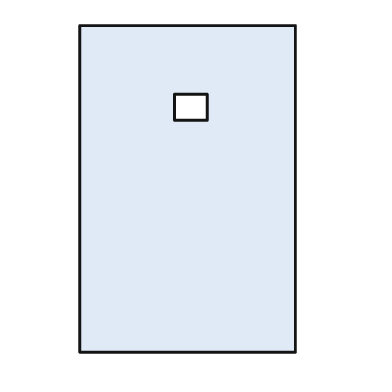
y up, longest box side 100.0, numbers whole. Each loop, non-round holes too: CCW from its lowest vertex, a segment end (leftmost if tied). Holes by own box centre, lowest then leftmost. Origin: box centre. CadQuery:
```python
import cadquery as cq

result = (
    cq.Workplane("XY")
    .moveTo(-33.0, -50.0)
    .lineTo(33.0, -50.0)
    .lineTo(33.0, 50.0)
    .lineTo(-33.0, 50.0)
    .close()
    .moveTo(-4.0, 21.0)
    .lineTo(6.0, 21.0)
    .lineTo(6.0, 29.0)
    .lineTo(-4.0, 29.0)
    .close()
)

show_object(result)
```